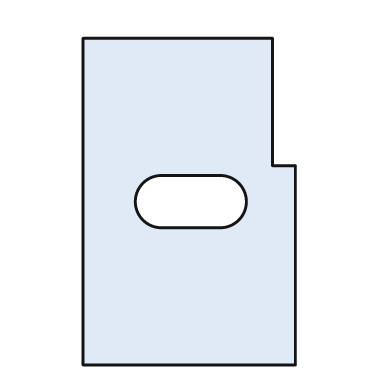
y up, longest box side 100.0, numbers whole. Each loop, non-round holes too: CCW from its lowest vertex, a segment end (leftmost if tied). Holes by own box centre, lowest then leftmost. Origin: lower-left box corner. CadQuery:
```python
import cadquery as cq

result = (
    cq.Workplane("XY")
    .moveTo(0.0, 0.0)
    .lineTo(65.0, 0.0)
    .lineTo(65.0, 61.0)
    .lineTo(58.0, 61.0)
    .lineTo(58.0, 100.0)
    .lineTo(0.0, 100.0)
    .close()
    .moveTo(24.0, 42.0)
    .lineTo(42.0, 42.0)
    .threePointArc((50.0, 50.0), (42.0, 58.0))
    .lineTo(24.0, 58.0)
    .threePointArc((16.0, 50.0), (24.0, 42.0))
    .close()
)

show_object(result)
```